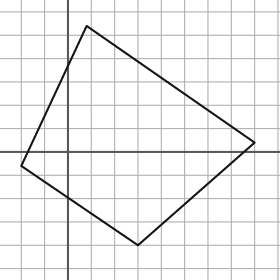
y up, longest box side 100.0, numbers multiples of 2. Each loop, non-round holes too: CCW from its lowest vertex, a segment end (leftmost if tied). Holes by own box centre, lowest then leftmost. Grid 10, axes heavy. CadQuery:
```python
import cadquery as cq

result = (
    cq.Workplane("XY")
    .moveTo(30.0, -40.0)
    .lineTo(80.0, 4.0)
    .lineTo(8.0, 54.0)
    .lineTo(-20.0, -6.0)
    .close()
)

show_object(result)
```